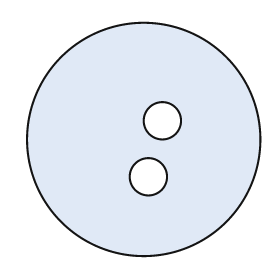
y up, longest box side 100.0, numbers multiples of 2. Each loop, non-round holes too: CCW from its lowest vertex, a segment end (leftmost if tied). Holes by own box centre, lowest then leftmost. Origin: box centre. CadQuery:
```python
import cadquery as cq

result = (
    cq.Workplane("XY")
    .moveTo(0.0, 0.0)
    .circle(50.0)
    .moveTo(2.0, -16.0)
    .circle(8.0)
    .moveTo(8.0, 8.0)
    .circle(8.0)
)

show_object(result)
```